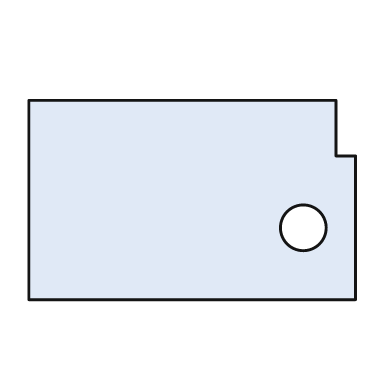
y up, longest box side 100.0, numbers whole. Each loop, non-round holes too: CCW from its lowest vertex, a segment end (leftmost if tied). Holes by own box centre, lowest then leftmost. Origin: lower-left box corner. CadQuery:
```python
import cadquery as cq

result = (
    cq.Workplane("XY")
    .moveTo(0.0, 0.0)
    .lineTo(100.0, 0.0)
    .lineTo(100.0, 44.0)
    .lineTo(94.0, 44.0)
    .lineTo(94.0, 61.0)
    .lineTo(0.0, 61.0)
    .close()
    .moveTo(84.0, 22.0)
    .circle(7.0)
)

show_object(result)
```